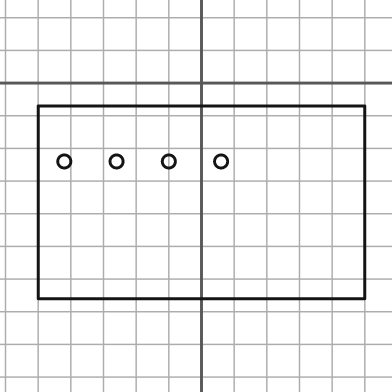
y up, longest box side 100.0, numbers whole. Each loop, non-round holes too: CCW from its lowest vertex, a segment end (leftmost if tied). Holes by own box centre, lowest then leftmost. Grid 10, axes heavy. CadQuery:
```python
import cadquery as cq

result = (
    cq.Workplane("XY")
    .moveTo(-50.0, -66.0)
    .lineTo(50.0, -66.0)
    .lineTo(50.0, -7.0)
    .lineTo(-50.0, -7.0)
    .close()
    .moveTo(-42.0, -24.0)
    .circle(2.0)
    .moveTo(-26.0, -24.0)
    .circle(2.0)
    .moveTo(-10.0, -24.0)
    .circle(2.0)
    .moveTo(6.0, -24.0)
    .circle(2.0)
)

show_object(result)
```